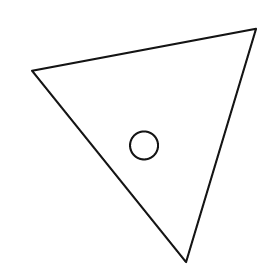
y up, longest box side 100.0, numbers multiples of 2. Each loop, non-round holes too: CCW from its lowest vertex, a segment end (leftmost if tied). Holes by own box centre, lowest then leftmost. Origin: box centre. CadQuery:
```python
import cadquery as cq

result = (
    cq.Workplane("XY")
    .moveTo(18.0, -50.0)
    .lineTo(48.0, 50.0)
    .lineTo(-48.0, 32.0)
    .close()
    .moveTo(0.0, 0.0)
    .circle(6.0)
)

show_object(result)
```